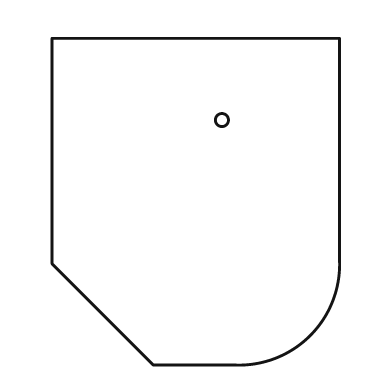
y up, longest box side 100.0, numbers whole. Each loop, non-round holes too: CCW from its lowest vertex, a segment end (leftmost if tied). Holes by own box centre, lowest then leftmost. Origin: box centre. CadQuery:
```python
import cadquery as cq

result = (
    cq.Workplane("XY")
    .moveTo(-13.0, -50.0)
    .lineTo(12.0, -50.0)
    .threePointArc((35.0, -41.0), (44.0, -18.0))
    .lineTo(44.0, 50.0)
    .lineTo(-44.0, 50.0)
    .lineTo(-44.0, -19.0)
    .close()
    .moveTo(8.0, 25.0)
    .circle(2.0)
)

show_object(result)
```